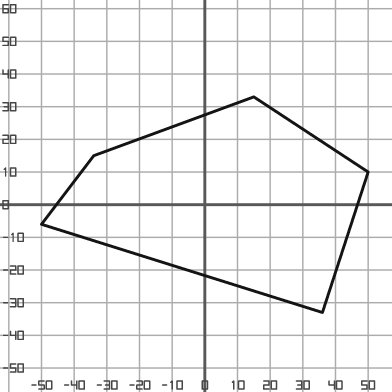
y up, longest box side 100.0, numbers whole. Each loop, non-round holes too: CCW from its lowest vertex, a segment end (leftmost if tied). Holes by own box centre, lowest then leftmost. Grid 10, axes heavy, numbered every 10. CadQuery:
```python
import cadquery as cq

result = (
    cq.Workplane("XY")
    .moveTo(36.0, -33.0)
    .lineTo(50.0, 10.0)
    .lineTo(15.0, 33.0)
    .lineTo(-34.0, 15.0)
    .lineTo(-50.0, -6.0)
    .close()
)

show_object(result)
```